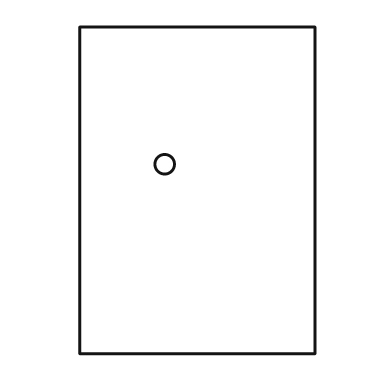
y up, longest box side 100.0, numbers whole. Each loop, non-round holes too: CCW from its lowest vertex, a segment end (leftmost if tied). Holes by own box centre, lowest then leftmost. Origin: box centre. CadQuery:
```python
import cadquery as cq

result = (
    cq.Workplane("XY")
    .moveTo(-36.0, -50.0)
    .lineTo(36.0, -50.0)
    .lineTo(36.0, 50.0)
    .lineTo(-36.0, 50.0)
    .close()
    .moveTo(-10.0, 8.0)
    .circle(3.0)
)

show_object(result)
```